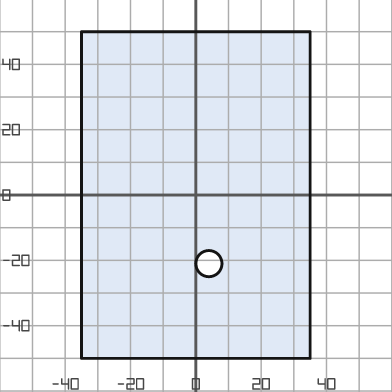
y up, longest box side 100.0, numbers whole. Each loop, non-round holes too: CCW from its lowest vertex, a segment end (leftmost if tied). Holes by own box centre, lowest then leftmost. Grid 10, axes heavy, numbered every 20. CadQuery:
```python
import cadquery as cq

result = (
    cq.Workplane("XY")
    .moveTo(-35.0, -50.0)
    .lineTo(35.0, -50.0)
    .lineTo(35.0, 50.0)
    .lineTo(-35.0, 50.0)
    .close()
    .moveTo(4.0, -21.0)
    .circle(4.0)
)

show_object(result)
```